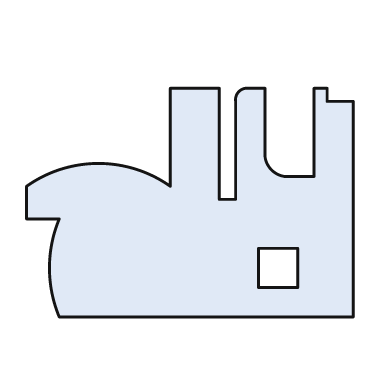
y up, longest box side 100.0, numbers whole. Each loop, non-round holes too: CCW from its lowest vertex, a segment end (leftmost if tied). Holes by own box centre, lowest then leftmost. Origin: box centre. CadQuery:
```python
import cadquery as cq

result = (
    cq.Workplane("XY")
    .moveTo(-40.0, -35.0)
    .lineTo(50.0, -35.0)
    .lineTo(50.0, 31.0)
    .lineTo(42.0, 31.0)
    .lineTo(42.0, 35.0)
    .lineTo(38.0, 35.0)
    .lineTo(38.0, 8.0)
    .lineTo(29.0, 8.0)
    .threePointArc((25.0, 10.0), (23.0, 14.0))
    .lineTo(23.0, 35.0)
    .lineTo(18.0, 35.0)
    .threePointArc((15.0, 34.0), (14.0, 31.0))
    .lineTo(14.0, 1.0)
    .lineTo(9.0, 1.0)
    .lineTo(9.0, 35.0)
    .lineTo(-6.0, 35.0)
    .lineTo(-6.0, 5.0)
    .threePointArc((-28.0, 12.0), (-50.0, 5.0))
    .lineTo(-50.0, -5.0)
    .lineTo(-40.0, -5.0)
    .threePointArc((-43.0, -20.0), (-40.0, -35.0))
    .close()
    .moveTo(21.0, -26.0)
    .lineTo(33.0, -26.0)
    .lineTo(33.0, -14.0)
    .lineTo(21.0, -14.0)
    .close()
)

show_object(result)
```